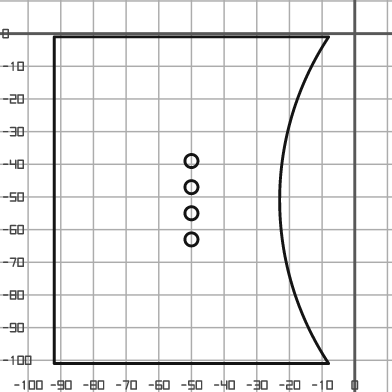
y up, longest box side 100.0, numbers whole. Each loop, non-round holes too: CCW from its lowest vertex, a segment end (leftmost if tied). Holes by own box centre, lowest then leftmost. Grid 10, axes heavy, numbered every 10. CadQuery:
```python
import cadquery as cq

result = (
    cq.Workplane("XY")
    .moveTo(-92.0, -101.0)
    .lineTo(-8.0, -101.0)
    .threePointArc((-23.0, -51.0), (-8.0, -1.0))
    .lineTo(-92.0, -1.0)
    .close()
    .moveTo(-50.0, -63.0)
    .circle(2.0)
    .moveTo(-50.0, -55.0)
    .circle(2.0)
    .moveTo(-50.0, -47.0)
    .circle(2.0)
    .moveTo(-50.0, -39.0)
    .circle(2.0)
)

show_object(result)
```